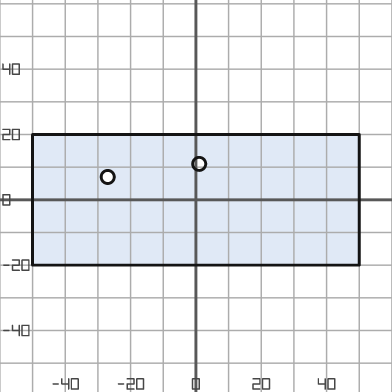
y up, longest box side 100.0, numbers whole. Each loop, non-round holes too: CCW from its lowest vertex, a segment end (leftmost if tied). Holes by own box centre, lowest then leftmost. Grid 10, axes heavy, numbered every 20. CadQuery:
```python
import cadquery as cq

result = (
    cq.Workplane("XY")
    .moveTo(-50.0, -20.0)
    .lineTo(50.0, -20.0)
    .lineTo(50.0, 20.0)
    .lineTo(-50.0, 20.0)
    .close()
    .moveTo(-27.0, 7.0)
    .circle(2.0)
    .moveTo(1.0, 11.0)
    .circle(2.0)
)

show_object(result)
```